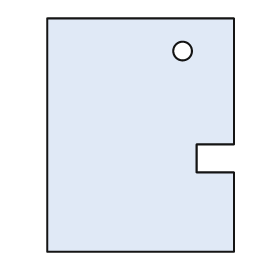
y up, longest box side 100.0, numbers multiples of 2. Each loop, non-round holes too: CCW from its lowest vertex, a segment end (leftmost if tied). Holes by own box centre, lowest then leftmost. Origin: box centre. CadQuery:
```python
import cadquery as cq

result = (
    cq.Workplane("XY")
    .moveTo(-40.0, -50.0)
    .lineTo(40.0, -50.0)
    .lineTo(40.0, -16.0)
    .lineTo(24.0, -16.0)
    .lineTo(24.0, -4.0)
    .lineTo(40.0, -4.0)
    .lineTo(40.0, 50.0)
    .lineTo(-40.0, 50.0)
    .close()
    .moveTo(18.0, 36.0)
    .circle(4.0)
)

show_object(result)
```